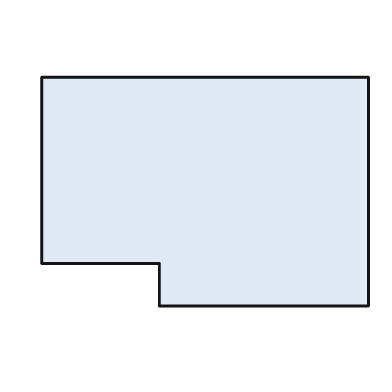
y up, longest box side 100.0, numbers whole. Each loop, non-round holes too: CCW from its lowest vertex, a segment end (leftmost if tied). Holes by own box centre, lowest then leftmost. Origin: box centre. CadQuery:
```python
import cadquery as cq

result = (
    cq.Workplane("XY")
    .moveTo(-14.0, -35.0)
    .lineTo(50.0, -35.0)
    .lineTo(50.0, 35.0)
    .lineTo(-50.0, 35.0)
    .lineTo(-50.0, -22.0)
    .lineTo(-14.0, -22.0)
    .close()
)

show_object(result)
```